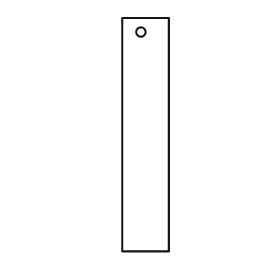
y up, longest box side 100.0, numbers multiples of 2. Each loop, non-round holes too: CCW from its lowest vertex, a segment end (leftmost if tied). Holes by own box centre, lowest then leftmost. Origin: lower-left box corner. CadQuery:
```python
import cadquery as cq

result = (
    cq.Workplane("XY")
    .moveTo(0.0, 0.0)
    .lineTo(20.0, 0.0)
    .lineTo(20.0, 100.0)
    .lineTo(0.0, 100.0)
    .close()
    .moveTo(8.0, 94.0)
    .circle(2.0)
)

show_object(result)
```